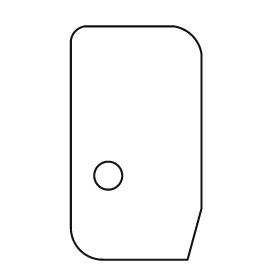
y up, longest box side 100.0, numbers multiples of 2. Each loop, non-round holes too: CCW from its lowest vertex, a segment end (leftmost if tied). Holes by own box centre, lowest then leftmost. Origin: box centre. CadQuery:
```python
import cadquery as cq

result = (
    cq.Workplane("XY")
    .moveTo(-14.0, -50.0)
    .lineTo(22.0, -50.0)
    .lineTo(28.0, -28.0)
    .lineTo(28.0, 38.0)
    .threePointArc((24.0, 46.0), (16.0, 50.0))
    .lineTo(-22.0, 50.0)
    .threePointArc((-26.0, 48.0), (-28.0, 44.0))
    .lineTo(-28.0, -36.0)
    .threePointArc((-24.0, -46.0), (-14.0, -50.0))
    .close()
    .moveTo(-12.0, -14.0)
    .circle(6.0)
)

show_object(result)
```